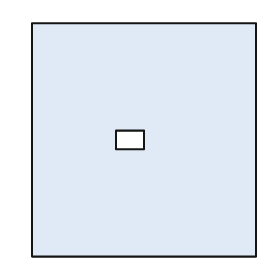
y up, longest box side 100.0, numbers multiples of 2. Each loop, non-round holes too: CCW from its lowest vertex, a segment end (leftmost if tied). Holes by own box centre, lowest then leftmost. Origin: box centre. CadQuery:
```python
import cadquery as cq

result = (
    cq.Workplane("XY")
    .moveTo(-48.0, -50.0)
    .lineTo(48.0, -50.0)
    .lineTo(48.0, 50.0)
    .lineTo(-48.0, 50.0)
    .close()
    .moveTo(-12.0, -4.0)
    .lineTo(0.0, -4.0)
    .lineTo(0.0, 4.0)
    .lineTo(-12.0, 4.0)
    .close()
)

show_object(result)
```